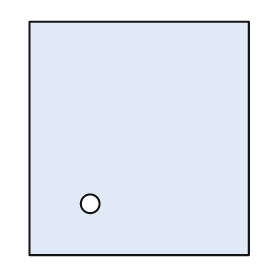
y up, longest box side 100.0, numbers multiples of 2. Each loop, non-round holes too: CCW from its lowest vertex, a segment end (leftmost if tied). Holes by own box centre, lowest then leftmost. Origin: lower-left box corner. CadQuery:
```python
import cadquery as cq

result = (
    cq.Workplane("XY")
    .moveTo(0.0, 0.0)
    .lineTo(94.0, 0.0)
    .lineTo(94.0, 100.0)
    .lineTo(0.0, 100.0)
    .close()
    .moveTo(26.0, 22.0)
    .circle(4.0)
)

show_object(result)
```